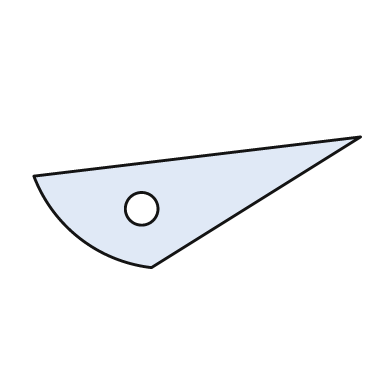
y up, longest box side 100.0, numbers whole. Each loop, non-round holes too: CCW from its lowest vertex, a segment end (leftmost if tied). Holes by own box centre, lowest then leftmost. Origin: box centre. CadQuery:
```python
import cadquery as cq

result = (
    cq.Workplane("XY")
    .moveTo(-14.0, -20.0)
    .lineTo(50.0, 20.0)
    .lineTo(-50.0, 8.0)
    .threePointArc((-36.0, -11.0), (-14.0, -20.0))
    .close()
    .moveTo(-17.0, -2.0)
    .circle(5.0)
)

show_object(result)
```